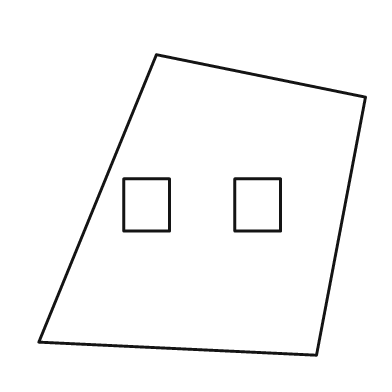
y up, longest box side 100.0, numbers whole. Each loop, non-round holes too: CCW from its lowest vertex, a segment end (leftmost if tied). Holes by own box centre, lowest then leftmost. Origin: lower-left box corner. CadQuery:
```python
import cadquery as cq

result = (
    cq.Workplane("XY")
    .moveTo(85.0, 0.0)
    .lineTo(100.0, 79.0)
    .lineTo(36.0, 92.0)
    .lineTo(0.0, 4.0)
    .close()
    .moveTo(26.0, 38.0)
    .lineTo(40.0, 38.0)
    .lineTo(40.0, 54.0)
    .lineTo(26.0, 54.0)
    .close()
    .moveTo(60.0, 38.0)
    .lineTo(74.0, 38.0)
    .lineTo(74.0, 54.0)
    .lineTo(60.0, 54.0)
    .close()
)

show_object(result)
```